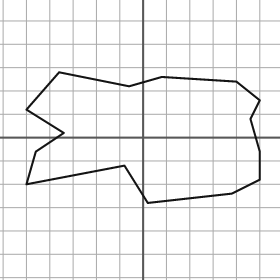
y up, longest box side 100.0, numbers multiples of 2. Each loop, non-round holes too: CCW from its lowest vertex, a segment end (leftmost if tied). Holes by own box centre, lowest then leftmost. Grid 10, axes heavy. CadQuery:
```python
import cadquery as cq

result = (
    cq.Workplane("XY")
    .moveTo(2.0, -28.0)
    .lineTo(38.0, -24.0)
    .lineTo(50.0, -18.0)
    .lineTo(50.0, -6.0)
    .lineTo(46.0, 8.0)
    .lineTo(50.0, 16.0)
    .lineTo(40.0, 24.0)
    .lineTo(8.0, 26.0)
    .lineTo(-6.0, 22.0)
    .lineTo(-36.0, 28.0)
    .lineTo(-50.0, 12.0)
    .lineTo(-34.0, 2.0)
    .lineTo(-46.0, -6.0)
    .lineTo(-50.0, -20.0)
    .lineTo(-8.0, -12.0)
    .close()
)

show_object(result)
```